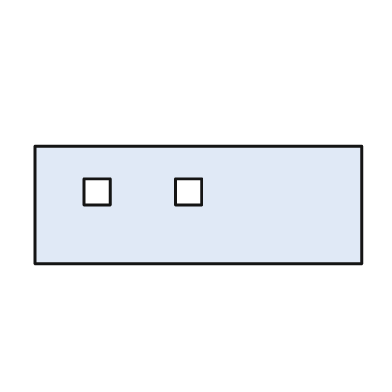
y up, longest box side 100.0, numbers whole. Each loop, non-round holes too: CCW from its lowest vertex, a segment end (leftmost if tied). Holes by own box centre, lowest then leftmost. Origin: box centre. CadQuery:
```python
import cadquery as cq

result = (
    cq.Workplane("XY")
    .moveTo(-50.0, -18.0)
    .lineTo(50.0, -18.0)
    .lineTo(50.0, 18.0)
    .lineTo(-50.0, 18.0)
    .close()
    .moveTo(-35.0, 0.0)
    .lineTo(-27.0, 0.0)
    .lineTo(-27.0, 8.0)
    .lineTo(-35.0, 8.0)
    .close()
    .moveTo(-7.0, 0.0)
    .lineTo(1.0, 0.0)
    .lineTo(1.0, 8.0)
    .lineTo(-7.0, 8.0)
    .close()
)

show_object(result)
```